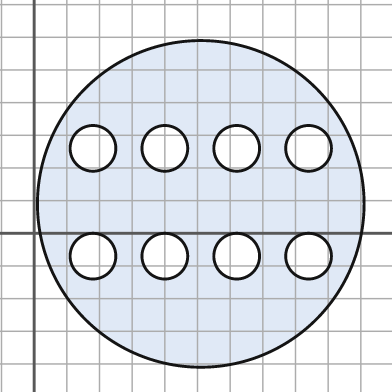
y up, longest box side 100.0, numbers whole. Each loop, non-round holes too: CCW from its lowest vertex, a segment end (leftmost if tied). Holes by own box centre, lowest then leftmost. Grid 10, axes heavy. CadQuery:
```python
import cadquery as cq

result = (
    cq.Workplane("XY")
    .moveTo(51.0, 9.0)
    .circle(50.0)
    .moveTo(18.0, -7.0)
    .circle(7.0)
    .moveTo(40.0, -7.0)
    .circle(7.0)
    .moveTo(62.0, -7.0)
    .circle(7.0)
    .moveTo(84.0, -7.0)
    .circle(7.0)
    .moveTo(18.0, 26.0)
    .circle(7.0)
    .moveTo(40.0, 26.0)
    .circle(7.0)
    .moveTo(62.0, 26.0)
    .circle(7.0)
    .moveTo(84.0, 26.0)
    .circle(7.0)
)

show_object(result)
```